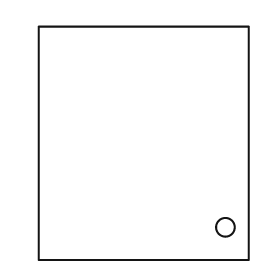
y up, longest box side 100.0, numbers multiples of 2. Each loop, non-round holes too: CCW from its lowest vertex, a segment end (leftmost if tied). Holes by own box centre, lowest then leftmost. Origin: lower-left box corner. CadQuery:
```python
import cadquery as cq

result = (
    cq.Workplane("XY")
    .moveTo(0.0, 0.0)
    .lineTo(90.0, 0.0)
    .lineTo(90.0, 100.0)
    .lineTo(0.0, 100.0)
    .close()
    .moveTo(80.0, 14.0)
    .circle(4.0)
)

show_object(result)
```